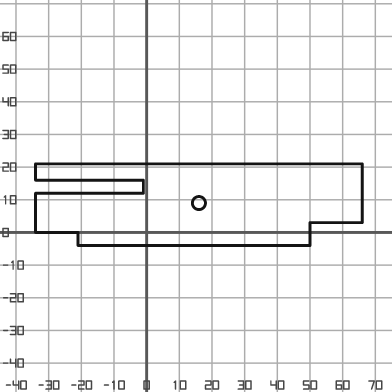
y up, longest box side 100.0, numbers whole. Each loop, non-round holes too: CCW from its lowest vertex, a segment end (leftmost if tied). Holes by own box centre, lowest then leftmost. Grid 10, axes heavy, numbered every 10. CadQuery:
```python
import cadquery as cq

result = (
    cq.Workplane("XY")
    .moveTo(-21.0, -4.0)
    .lineTo(50.0, -4.0)
    .lineTo(50.0, 3.0)
    .lineTo(66.0, 3.0)
    .lineTo(66.0, 21.0)
    .lineTo(-34.0, 21.0)
    .lineTo(-34.0, 16.0)
    .lineTo(-1.0, 16.0)
    .lineTo(-1.0, 12.0)
    .lineTo(-34.0, 12.0)
    .lineTo(-34.0, 0.0)
    .lineTo(-21.0, 0.0)
    .close()
    .moveTo(16.0, 9.0)
    .circle(2.0)
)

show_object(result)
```